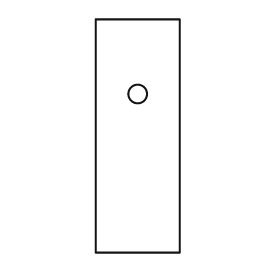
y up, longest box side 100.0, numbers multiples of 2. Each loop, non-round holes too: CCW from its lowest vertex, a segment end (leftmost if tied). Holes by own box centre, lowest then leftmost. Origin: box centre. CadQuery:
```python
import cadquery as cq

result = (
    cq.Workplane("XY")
    .moveTo(-18.0, -50.0)
    .lineTo(18.0, -50.0)
    .lineTo(18.0, 50.0)
    .lineTo(-18.0, 50.0)
    .close()
    .moveTo(0.0, 18.0)
    .circle(4.0)
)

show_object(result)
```